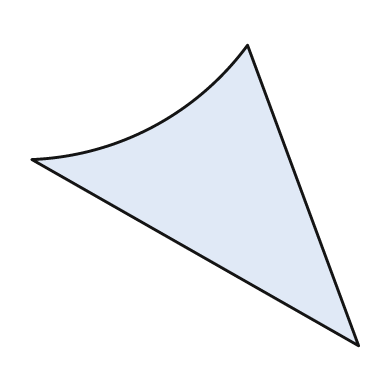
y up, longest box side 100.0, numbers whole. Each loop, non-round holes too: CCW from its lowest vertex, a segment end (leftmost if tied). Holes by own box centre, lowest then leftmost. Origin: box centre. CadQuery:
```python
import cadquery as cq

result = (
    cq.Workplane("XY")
    .moveTo(50.0, -46.0)
    .lineTo(16.0, 46.0)
    .threePointArc((-13.0, 21.0), (-50.0, 11.0))
    .close()
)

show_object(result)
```